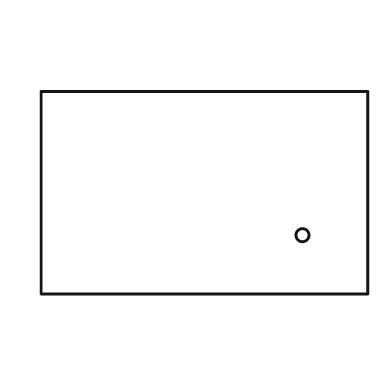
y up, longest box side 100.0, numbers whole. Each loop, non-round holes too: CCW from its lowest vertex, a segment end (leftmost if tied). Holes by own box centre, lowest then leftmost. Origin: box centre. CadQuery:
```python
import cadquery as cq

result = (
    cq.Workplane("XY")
    .moveTo(-50.0, -31.0)
    .lineTo(50.0, -31.0)
    .lineTo(50.0, 31.0)
    .lineTo(-50.0, 31.0)
    .close()
    .moveTo(30.0, -13.0)
    .circle(2.0)
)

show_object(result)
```